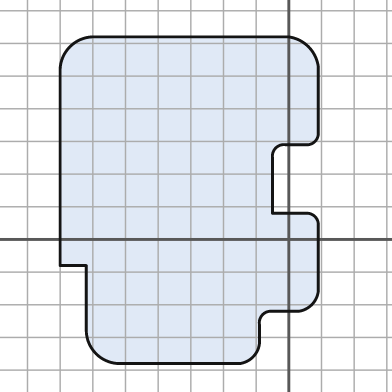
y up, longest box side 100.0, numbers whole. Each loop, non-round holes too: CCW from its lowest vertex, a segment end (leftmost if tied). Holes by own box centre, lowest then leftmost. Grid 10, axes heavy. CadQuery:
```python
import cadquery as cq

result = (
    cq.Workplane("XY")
    .moveTo(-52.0, -38.0)
    .lineTo(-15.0, -38.0)
    .threePointArc((-11.0, -36.0), (-9.0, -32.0))
    .lineTo(-9.0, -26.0)
    .threePointArc((-8.0, -23.0), (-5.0, -22.0))
    .lineTo(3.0, -22.0)
    .threePointArc((7.0, -20.0), (9.0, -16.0))
    .lineTo(9.0, 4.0)
    .threePointArc((8.0, 7.0), (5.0, 8.0))
    .lineTo(-5.0, 8.0)
    .lineTo(-5.0, 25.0)
    .threePointArc((-4.0, 28.0), (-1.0, 29.0))
    .lineTo(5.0, 29.0)
    .threePointArc((8.0, 30.0), (9.0, 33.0))
    .lineTo(9.0, 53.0)
    .threePointArc((6.0, 59.0), (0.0, 62.0))
    .lineTo(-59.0, 62.0)
    .threePointArc((-67.0, 59.0), (-70.0, 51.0))
    .lineTo(-70.0, -8.0)
    .lineTo(-62.0, -8.0)
    .lineTo(-62.0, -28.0)
    .threePointArc((-59.0, -35.0), (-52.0, -38.0))
    .close()
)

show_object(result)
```